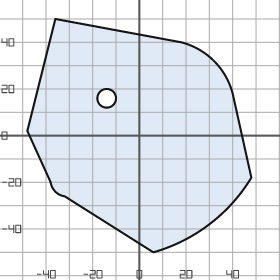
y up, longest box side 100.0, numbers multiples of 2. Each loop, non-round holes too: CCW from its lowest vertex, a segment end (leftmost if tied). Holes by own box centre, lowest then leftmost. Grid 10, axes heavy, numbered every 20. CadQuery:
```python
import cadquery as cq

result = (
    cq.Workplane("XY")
    .moveTo(6.0, -50.0)
    .threePointArc((30.0, -38.0), (48.0, -18.0))
    .lineTo(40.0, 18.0)
    .threePointArc((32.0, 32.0), (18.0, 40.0))
    .lineTo(-36.0, 50.0)
    .lineTo(-48.0, 2.0)
    .lineTo(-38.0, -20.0)
    .threePointArc((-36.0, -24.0), (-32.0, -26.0))
    .close()
    .moveTo(-14.0, 16.0)
    .circle(4.0)
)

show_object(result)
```